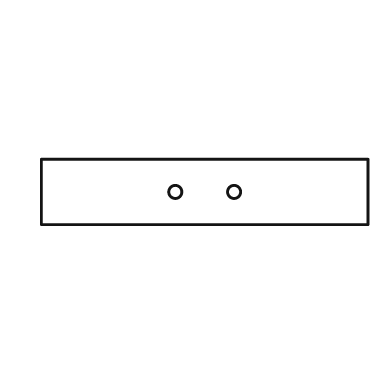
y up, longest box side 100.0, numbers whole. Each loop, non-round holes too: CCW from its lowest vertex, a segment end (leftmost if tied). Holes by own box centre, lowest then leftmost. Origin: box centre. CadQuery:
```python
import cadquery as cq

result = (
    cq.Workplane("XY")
    .moveTo(-50.0, -10.0)
    .lineTo(50.0, -10.0)
    .lineTo(50.0, 10.0)
    .lineTo(-50.0, 10.0)
    .close()
    .moveTo(-9.0, 0.0)
    .circle(2.0)
    .moveTo(9.0, 0.0)
    .circle(2.0)
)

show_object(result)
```